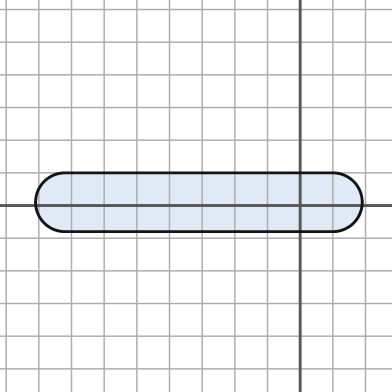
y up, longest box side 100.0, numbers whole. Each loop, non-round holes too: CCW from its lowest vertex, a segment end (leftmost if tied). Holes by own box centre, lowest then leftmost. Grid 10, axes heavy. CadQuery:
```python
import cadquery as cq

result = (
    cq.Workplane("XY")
    .moveTo(-72.0, -8.0)
    .lineTo(10.0, -8.0)
    .threePointArc((19.0, 1.0), (10.0, 10.0))
    .lineTo(-72.0, 10.0)
    .threePointArc((-81.0, 1.0), (-72.0, -8.0))
    .close()
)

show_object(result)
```